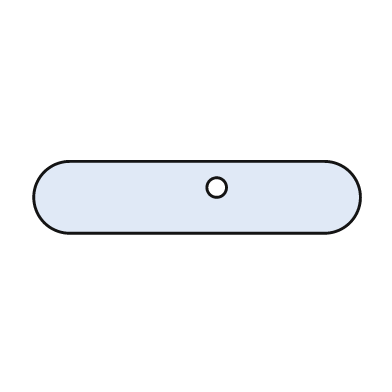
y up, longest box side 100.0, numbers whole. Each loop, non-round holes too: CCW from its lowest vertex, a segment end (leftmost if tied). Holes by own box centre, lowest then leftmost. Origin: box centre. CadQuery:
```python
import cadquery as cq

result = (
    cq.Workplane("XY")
    .moveTo(-39.0, -11.0)
    .lineTo(39.0, -11.0)
    .threePointArc((50.0, 0.0), (39.0, 11.0))
    .lineTo(-39.0, 11.0)
    .threePointArc((-50.0, 0.0), (-39.0, -11.0))
    .close()
    .moveTo(6.0, 3.0)
    .circle(3.0)
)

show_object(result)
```